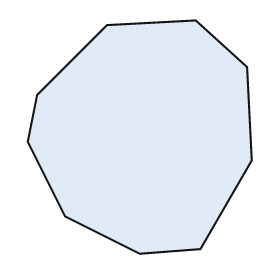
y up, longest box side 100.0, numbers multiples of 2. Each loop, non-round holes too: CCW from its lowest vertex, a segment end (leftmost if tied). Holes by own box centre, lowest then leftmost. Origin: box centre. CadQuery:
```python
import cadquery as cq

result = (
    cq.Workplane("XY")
    .moveTo(0.0, -50.0)
    .lineTo(26.0, -48.0)
    .lineTo(48.0, -10.0)
    .lineTo(46.0, 30.0)
    .lineTo(24.0, 50.0)
    .lineTo(-14.0, 48.0)
    .lineTo(-44.0, 18.0)
    .lineTo(-48.0, -2.0)
    .lineTo(-32.0, -34.0)
    .close()
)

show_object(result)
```